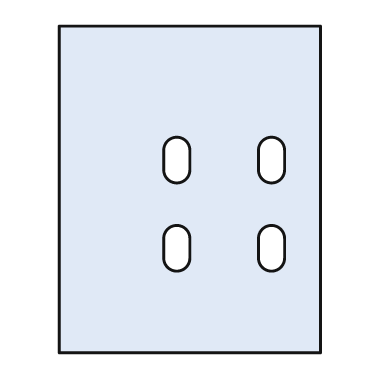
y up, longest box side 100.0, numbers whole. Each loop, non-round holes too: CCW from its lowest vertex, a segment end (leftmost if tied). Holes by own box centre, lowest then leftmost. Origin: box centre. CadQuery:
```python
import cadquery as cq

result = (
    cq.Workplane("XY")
    .moveTo(-40.0, -50.0)
    .lineTo(40.0, -50.0)
    .lineTo(40.0, 50.0)
    .lineTo(-40.0, 50.0)
    .close()
    .moveTo(-8.0, -21.0)
    .threePointArc((-4.0, -25.0), (0.0, -21.0))
    .lineTo(0.0, -15.0)
    .threePointArc((-4.0, -11.0), (-8.0, -15.0))
    .close()
    .moveTo(21.0, -21.0)
    .threePointArc((25.0, -25.0), (29.0, -21.0))
    .lineTo(29.0, -15.0)
    .threePointArc((25.0, -11.0), (21.0, -15.0))
    .close()
    .moveTo(-8.0, 6.0)
    .threePointArc((-4.0, 2.0), (0.0, 6.0))
    .lineTo(0.0, 12.0)
    .threePointArc((-4.0, 16.0), (-8.0, 12.0))
    .close()
    .moveTo(21.0, 6.0)
    .threePointArc((25.0, 2.0), (29.0, 6.0))
    .lineTo(29.0, 12.0)
    .threePointArc((25.0, 16.0), (21.0, 12.0))
    .close()
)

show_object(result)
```